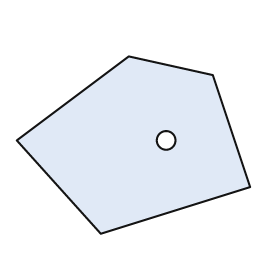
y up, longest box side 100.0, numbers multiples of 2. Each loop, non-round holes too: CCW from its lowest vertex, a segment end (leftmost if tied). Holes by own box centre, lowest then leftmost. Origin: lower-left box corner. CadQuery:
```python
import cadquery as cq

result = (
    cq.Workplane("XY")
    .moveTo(36.0, 0.0)
    .lineTo(100.0, 20.0)
    .lineTo(84.0, 68.0)
    .lineTo(48.0, 76.0)
    .lineTo(0.0, 40.0)
    .close()
    .moveTo(64.0, 40.0)
    .circle(4.0)
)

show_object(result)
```